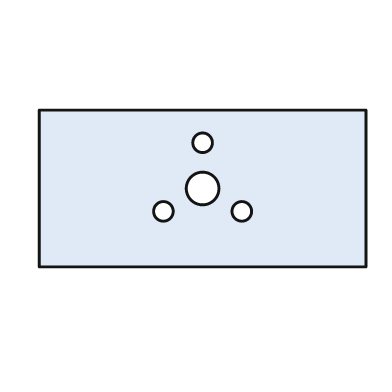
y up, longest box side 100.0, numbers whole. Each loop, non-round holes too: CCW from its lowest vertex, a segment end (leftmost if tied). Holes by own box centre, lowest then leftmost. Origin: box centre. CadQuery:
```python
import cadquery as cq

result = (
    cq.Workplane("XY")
    .moveTo(-50.0, -24.0)
    .lineTo(50.0, -24.0)
    .lineTo(50.0, 24.0)
    .lineTo(-50.0, 24.0)
    .close()
    .moveTo(-12.0, -7.0)
    .circle(3.0)
    .moveTo(12.0, -7.0)
    .circle(3.0)
    .moveTo(0.0, 0.0)
    .circle(5.0)
    .moveTo(0.0, 14.0)
    .circle(3.0)
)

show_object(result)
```